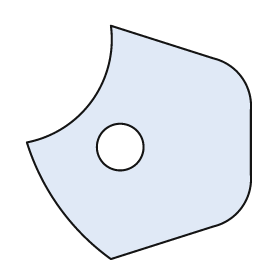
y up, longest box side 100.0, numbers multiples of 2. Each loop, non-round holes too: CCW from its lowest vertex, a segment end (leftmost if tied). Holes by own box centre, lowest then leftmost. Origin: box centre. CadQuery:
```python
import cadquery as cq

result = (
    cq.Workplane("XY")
    .moveTo(-12.0, -50.0)
    .lineTo(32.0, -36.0)
    .threePointArc((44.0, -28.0), (48.0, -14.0))
    .lineTo(48.0, 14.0)
    .threePointArc((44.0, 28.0), (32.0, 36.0))
    .lineTo(-12.0, 50.0)
    .threePointArc((-20.0, 18.0), (-48.0, 0.0))
    .threePointArc((-34.0, -28.0), (-12.0, -50.0))
    .close()
    .moveTo(-8.0, -2.0)
    .circle(10.0)
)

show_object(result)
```